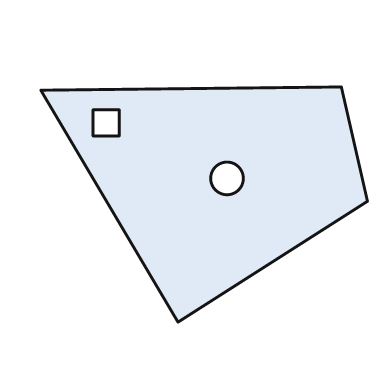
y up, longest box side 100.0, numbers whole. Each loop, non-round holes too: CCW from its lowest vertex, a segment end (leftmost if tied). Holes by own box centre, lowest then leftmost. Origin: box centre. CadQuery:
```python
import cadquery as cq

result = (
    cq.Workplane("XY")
    .moveTo(-8.0, -36.0)
    .lineTo(50.0, 1.0)
    .lineTo(42.0, 36.0)
    .lineTo(-50.0, 35.0)
    .close()
    .moveTo(7.0, 8.0)
    .circle(5.0)
    .moveTo(-34.0, 21.0)
    .lineTo(-26.0, 21.0)
    .lineTo(-26.0, 29.0)
    .lineTo(-34.0, 29.0)
    .close()
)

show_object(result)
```